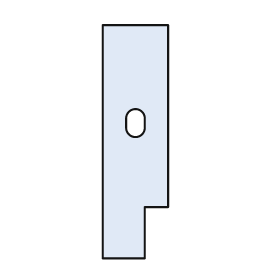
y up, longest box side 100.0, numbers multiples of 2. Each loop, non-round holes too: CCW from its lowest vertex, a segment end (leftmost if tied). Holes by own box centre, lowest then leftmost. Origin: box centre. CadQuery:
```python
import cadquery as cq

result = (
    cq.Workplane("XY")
    .moveTo(-14.0, -50.0)
    .lineTo(4.0, -50.0)
    .lineTo(4.0, -28.0)
    .lineTo(14.0, -28.0)
    .lineTo(14.0, 50.0)
    .lineTo(-14.0, 50.0)
    .close()
    .moveTo(-4.0, 6.0)
    .threePointArc((0.0, 2.0), (4.0, 6.0))
    .lineTo(4.0, 10.0)
    .threePointArc((0.0, 14.0), (-4.0, 10.0))
    .close()
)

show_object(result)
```